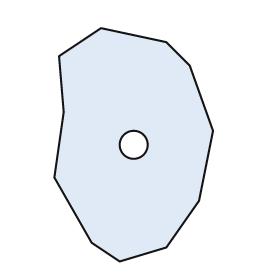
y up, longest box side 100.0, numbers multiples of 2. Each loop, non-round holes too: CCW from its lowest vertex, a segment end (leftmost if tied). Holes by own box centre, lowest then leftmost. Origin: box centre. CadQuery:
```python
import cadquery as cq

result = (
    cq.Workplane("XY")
    .moveTo(-6.0, -50.0)
    .lineTo(14.0, -44.0)
    .lineTo(28.0, -24.0)
    .lineTo(34.0, 6.0)
    .lineTo(24.0, 34.0)
    .lineTo(14.0, 44.0)
    .lineTo(-14.0, 50.0)
    .lineTo(-32.0, 38.0)
    .lineTo(-30.0, 14.0)
    .lineTo(-34.0, -14.0)
    .lineTo(-18.0, -42.0)
    .close()
    .moveTo(0.0, 0.0)
    .circle(6.0)
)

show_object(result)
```